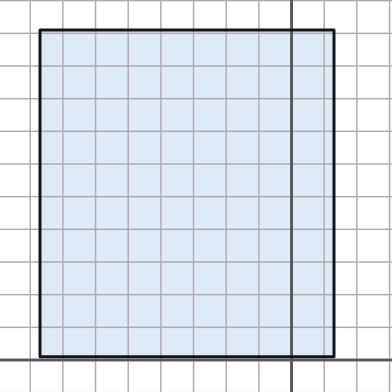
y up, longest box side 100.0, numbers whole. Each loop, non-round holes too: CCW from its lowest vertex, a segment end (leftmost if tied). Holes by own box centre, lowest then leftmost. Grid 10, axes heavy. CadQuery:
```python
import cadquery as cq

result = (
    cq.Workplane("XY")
    .moveTo(-77.0, 1.0)
    .lineTo(13.0, 1.0)
    .lineTo(13.0, 101.0)
    .lineTo(-77.0, 101.0)
    .close()
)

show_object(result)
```